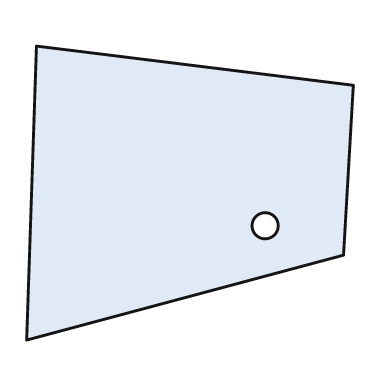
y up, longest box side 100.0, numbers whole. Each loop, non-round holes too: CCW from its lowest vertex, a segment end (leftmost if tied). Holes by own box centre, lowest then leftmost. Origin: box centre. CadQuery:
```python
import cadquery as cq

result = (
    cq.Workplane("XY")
    .moveTo(-50.0, -45.0)
    .lineTo(47.0, -19.0)
    .lineTo(50.0, 33.0)
    .lineTo(-47.0, 45.0)
    .close()
    .moveTo(23.0, -10.0)
    .circle(4.0)
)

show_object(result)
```